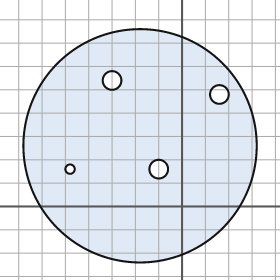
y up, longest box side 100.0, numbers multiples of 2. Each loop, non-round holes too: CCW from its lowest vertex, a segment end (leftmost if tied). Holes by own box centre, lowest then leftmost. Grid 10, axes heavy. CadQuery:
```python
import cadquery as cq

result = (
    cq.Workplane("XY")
    .moveTo(-18.0, 26.0)
    .circle(50.0)
    .moveTo(-48.0, 16.0)
    .circle(2.0)
    .moveTo(-10.0, 16.0)
    .circle(4.0)
    .moveTo(16.0, 48.0)
    .circle(4.0)
    .moveTo(-30.0, 54.0)
    .circle(4.0)
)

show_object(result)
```